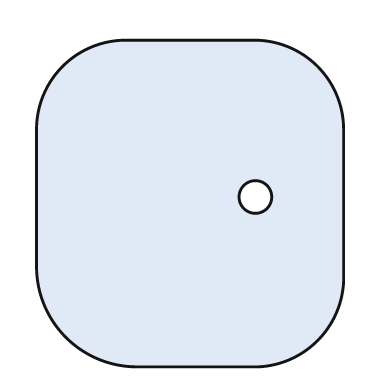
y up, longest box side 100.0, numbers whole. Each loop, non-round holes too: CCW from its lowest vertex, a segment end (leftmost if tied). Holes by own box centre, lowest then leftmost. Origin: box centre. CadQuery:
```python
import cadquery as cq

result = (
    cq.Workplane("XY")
    .moveTo(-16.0, -50.0)
    .lineTo(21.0, -50.0)
    .threePointArc((39.0, -42.0), (47.0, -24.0))
    .lineTo(47.0, 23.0)
    .threePointArc((39.0, 42.0), (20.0, 50.0))
    .lineTo(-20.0, 50.0)
    .threePointArc((-39.0, 42.0), (-47.0, 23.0))
    .lineTo(-47.0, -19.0)
    .threePointArc((-38.0, -41.0), (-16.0, -50.0))
    .close()
    .moveTo(20.0, 2.0)
    .circle(5.0)
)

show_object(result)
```